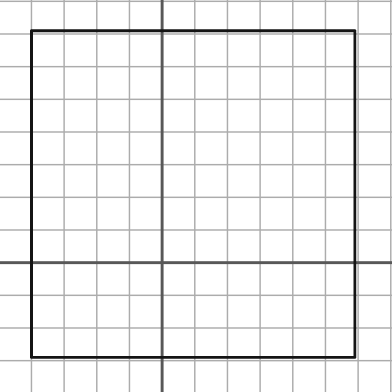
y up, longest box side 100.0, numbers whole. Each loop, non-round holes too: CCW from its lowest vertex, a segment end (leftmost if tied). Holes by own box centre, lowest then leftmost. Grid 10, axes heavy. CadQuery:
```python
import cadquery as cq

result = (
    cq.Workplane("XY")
    .moveTo(-40.0, -29.0)
    .lineTo(59.0, -29.0)
    .lineTo(59.0, 71.0)
    .lineTo(-40.0, 71.0)
    .close()
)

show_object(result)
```